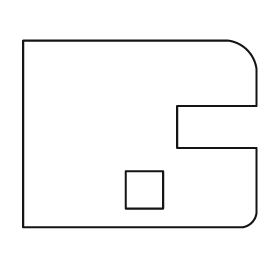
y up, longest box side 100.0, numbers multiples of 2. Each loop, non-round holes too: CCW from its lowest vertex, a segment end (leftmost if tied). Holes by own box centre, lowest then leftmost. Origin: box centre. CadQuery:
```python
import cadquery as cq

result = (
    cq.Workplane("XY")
    .moveTo(-50.0, -40.0)
    .lineTo(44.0, -40.0)
    .threePointArc((48.0, -38.0), (50.0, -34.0))
    .lineTo(50.0, -6.0)
    .lineTo(16.0, -6.0)
    .lineTo(16.0, 12.0)
    .lineTo(50.0, 12.0)
    .lineTo(50.0, 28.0)
    .threePointArc((46.0, 36.0), (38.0, 40.0))
    .lineTo(-50.0, 40.0)
    .close()
    .moveTo(-6.0, -32.0)
    .lineTo(10.0, -32.0)
    .lineTo(10.0, -16.0)
    .lineTo(-6.0, -16.0)
    .close()
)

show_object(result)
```